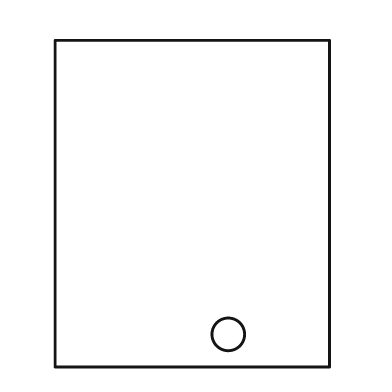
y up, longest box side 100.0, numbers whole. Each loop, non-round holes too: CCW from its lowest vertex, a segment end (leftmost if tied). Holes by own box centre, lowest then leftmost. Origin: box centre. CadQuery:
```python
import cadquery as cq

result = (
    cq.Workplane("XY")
    .moveTo(-42.0, -50.0)
    .lineTo(42.0, -50.0)
    .lineTo(42.0, 50.0)
    .lineTo(-42.0, 50.0)
    .close()
    .moveTo(11.0, -40.0)
    .circle(5.0)
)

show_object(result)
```